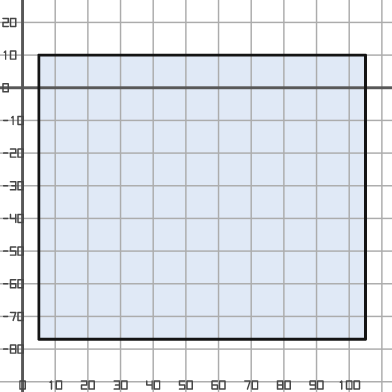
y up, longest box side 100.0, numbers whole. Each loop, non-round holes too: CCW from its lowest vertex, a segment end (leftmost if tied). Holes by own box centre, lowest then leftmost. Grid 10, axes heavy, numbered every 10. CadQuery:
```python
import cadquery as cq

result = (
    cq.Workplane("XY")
    .moveTo(5.0, -77.0)
    .lineTo(105.0, -77.0)
    .lineTo(105.0, 10.0)
    .lineTo(5.0, 10.0)
    .close()
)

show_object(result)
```